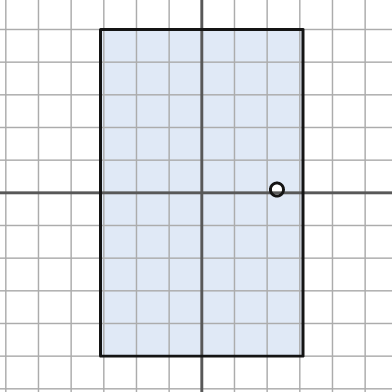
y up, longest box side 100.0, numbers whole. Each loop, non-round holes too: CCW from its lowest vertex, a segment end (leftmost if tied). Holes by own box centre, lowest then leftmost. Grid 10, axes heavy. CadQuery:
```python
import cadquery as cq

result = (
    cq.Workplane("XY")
    .moveTo(-31.0, -50.0)
    .lineTo(31.0, -50.0)
    .lineTo(31.0, 50.0)
    .lineTo(-31.0, 50.0)
    .close()
    .moveTo(23.0, 1.0)
    .circle(2.0)
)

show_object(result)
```